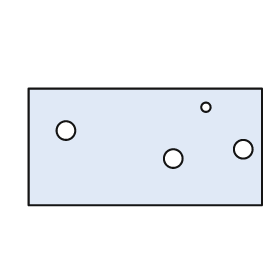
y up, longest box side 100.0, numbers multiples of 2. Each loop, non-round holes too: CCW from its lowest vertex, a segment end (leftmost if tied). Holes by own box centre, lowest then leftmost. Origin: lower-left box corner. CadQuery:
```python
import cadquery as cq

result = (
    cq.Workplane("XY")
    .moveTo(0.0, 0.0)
    .lineTo(100.0, 0.0)
    .lineTo(100.0, 50.0)
    .lineTo(0.0, 50.0)
    .close()
    .moveTo(62.0, 20.0)
    .circle(4.0)
    .moveTo(92.0, 24.0)
    .circle(4.0)
    .moveTo(16.0, 32.0)
    .circle(4.0)
    .moveTo(76.0, 42.0)
    .circle(2.0)
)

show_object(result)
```